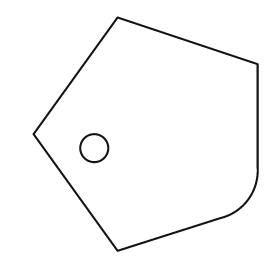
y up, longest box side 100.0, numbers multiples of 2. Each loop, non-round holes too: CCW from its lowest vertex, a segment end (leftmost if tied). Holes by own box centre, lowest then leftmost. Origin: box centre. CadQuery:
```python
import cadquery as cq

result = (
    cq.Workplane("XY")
    .moveTo(-12.0, -50.0)
    .lineTo(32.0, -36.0)
    .threePointArc((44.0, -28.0), (48.0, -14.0))
    .lineTo(48.0, 30.0)
    .lineTo(-12.0, 50.0)
    .lineTo(-48.0, 0.0)
    .close()
    .moveTo(-22.0, -6.0)
    .circle(6.0)
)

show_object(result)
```